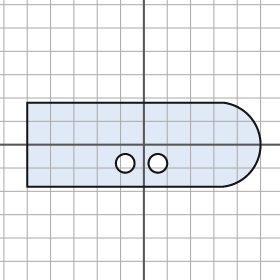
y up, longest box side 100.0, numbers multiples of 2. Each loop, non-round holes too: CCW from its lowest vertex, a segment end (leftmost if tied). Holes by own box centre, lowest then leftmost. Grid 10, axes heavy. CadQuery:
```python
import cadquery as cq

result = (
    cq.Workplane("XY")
    .moveTo(-50.0, -18.0)
    .lineTo(34.0, -18.0)
    .threePointArc((50.0, 0.0), (34.0, 18.0))
    .lineTo(-50.0, 18.0)
    .close()
    .moveTo(-8.0, -8.0)
    .circle(4.0)
    .moveTo(6.0, -8.0)
    .circle(4.0)
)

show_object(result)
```